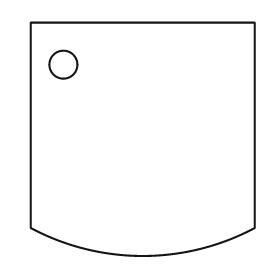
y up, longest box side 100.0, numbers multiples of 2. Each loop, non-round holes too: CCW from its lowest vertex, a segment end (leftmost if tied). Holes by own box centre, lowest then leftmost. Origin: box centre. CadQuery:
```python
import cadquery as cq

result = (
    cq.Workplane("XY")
    .moveTo(-48.0, -38.0)
    .threePointArc((0.0, -50.0), (48.0, -38.0))
    .lineTo(48.0, 50.0)
    .lineTo(-48.0, 50.0)
    .close()
    .moveTo(-34.0, 32.0)
    .circle(6.0)
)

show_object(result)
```